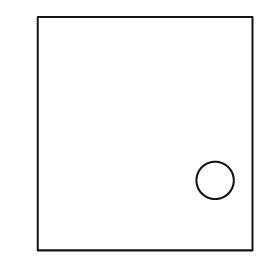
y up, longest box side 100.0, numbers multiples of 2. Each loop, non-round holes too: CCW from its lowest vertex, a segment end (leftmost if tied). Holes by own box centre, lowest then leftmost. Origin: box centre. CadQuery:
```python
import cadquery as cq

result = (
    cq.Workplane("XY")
    .moveTo(-46.0, -50.0)
    .lineTo(46.0, -50.0)
    .lineTo(46.0, 50.0)
    .lineTo(-46.0, 50.0)
    .close()
    .moveTo(30.0, -20.0)
    .circle(8.0)
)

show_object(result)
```